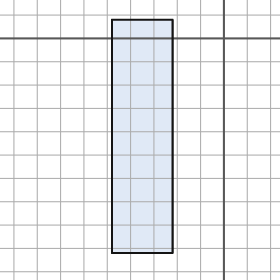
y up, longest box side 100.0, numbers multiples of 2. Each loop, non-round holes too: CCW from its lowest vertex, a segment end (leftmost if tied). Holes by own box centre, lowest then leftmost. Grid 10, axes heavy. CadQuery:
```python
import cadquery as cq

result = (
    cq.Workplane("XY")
    .moveTo(-48.0, -92.0)
    .lineTo(-22.0, -92.0)
    .lineTo(-22.0, 8.0)
    .lineTo(-48.0, 8.0)
    .close()
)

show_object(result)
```